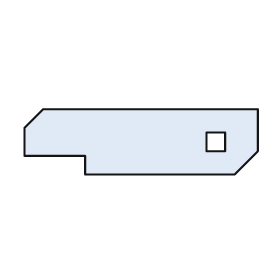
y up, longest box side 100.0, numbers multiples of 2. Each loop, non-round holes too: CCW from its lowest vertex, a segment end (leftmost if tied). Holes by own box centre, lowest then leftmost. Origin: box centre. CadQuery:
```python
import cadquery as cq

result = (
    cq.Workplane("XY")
    .moveTo(-24.0, -14.0)
    .lineTo(40.0, -14.0)
    .lineTo(50.0, -4.0)
    .lineTo(50.0, 14.0)
    .lineTo(-42.0, 14.0)
    .lineTo(-50.0, 6.0)
    .lineTo(-50.0, -6.0)
    .lineTo(-24.0, -6.0)
    .close()
    .moveTo(28.0, -4.0)
    .lineTo(36.0, -4.0)
    .lineTo(36.0, 4.0)
    .lineTo(28.0, 4.0)
    .close()
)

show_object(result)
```